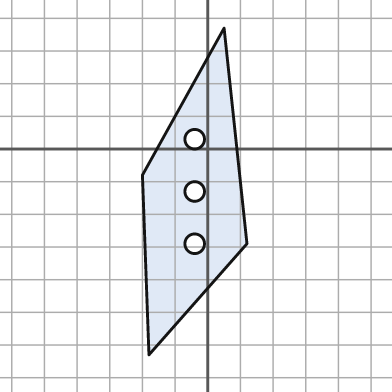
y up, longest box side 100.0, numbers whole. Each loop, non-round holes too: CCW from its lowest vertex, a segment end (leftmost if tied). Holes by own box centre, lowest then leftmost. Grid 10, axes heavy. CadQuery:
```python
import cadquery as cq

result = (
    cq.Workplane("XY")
    .moveTo(-18.0, -63.0)
    .lineTo(12.0, -29.0)
    .lineTo(5.0, 37.0)
    .lineTo(-20.0, -8.0)
    .close()
    .moveTo(-4.0, -29.0)
    .circle(3.0)
    .moveTo(-4.0, -13.0)
    .circle(3.0)
    .moveTo(-4.0, 3.0)
    .circle(3.0)
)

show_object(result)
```